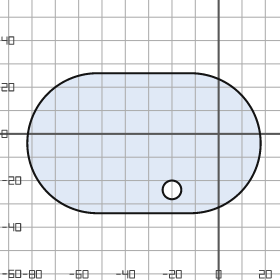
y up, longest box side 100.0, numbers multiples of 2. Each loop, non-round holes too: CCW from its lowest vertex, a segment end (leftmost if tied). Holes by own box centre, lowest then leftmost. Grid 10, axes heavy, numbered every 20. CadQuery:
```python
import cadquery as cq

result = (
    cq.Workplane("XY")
    .moveTo(-52.0, -34.0)
    .lineTo(-12.0, -34.0)
    .threePointArc((18.0, -4.0), (-12.0, 26.0))
    .lineTo(-52.0, 26.0)
    .threePointArc((-82.0, -4.0), (-52.0, -34.0))
    .close()
    .moveTo(-20.0, -24.0)
    .circle(4.0)
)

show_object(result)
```